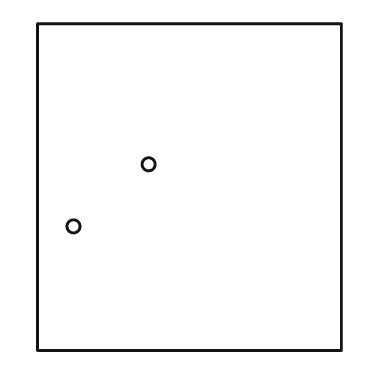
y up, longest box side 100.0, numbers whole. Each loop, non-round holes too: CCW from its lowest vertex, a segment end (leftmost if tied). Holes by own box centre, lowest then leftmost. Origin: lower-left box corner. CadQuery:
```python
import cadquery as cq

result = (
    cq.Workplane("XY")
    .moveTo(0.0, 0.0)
    .lineTo(93.0, 0.0)
    .lineTo(93.0, 100.0)
    .lineTo(0.0, 100.0)
    .close()
    .moveTo(11.0, 38.0)
    .circle(2.0)
    .moveTo(34.0, 57.0)
    .circle(2.0)
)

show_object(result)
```